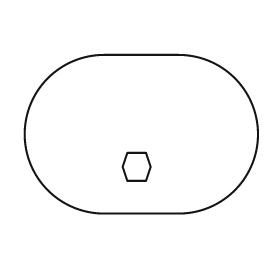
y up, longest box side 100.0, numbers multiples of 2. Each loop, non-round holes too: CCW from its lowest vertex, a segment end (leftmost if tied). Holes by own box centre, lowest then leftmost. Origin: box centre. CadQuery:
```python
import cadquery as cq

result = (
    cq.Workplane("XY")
    .moveTo(-16.0, -34.0)
    .lineTo(16.0, -34.0)
    .threePointArc((50.0, 0.0), (16.0, 34.0))
    .lineTo(-16.0, 34.0)
    .threePointArc((-50.0, 0.0), (-16.0, -34.0))
    .close()
    .moveTo(-6.0, -20.0)
    .lineTo(2.0, -20.0)
    .lineTo(4.0, -14.0)
    .lineTo(2.0, -8.0)
    .lineTo(-6.0, -8.0)
    .lineTo(-8.0, -14.0)
    .close()
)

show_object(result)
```